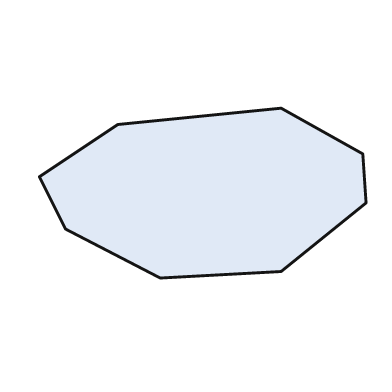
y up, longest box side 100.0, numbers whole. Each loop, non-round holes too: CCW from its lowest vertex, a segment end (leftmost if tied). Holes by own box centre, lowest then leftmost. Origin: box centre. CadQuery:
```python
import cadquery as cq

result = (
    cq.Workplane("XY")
    .moveTo(-13.0, -26.0)
    .lineTo(24.0, -24.0)
    .lineTo(50.0, -3.0)
    .lineTo(49.0, 12.0)
    .lineTo(24.0, 26.0)
    .lineTo(-26.0, 21.0)
    .lineTo(-50.0, 5.0)
    .lineTo(-42.0, -11.0)
    .close()
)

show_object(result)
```